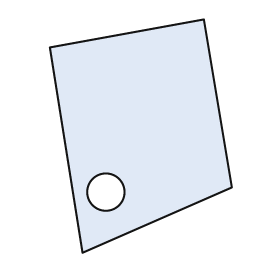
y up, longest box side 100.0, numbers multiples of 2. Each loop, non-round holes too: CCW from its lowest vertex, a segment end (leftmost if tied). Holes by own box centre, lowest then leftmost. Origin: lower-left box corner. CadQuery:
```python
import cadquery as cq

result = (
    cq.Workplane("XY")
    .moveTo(14.0, 0.0)
    .lineTo(78.0, 28.0)
    .lineTo(66.0, 100.0)
    .lineTo(0.0, 88.0)
    .close()
    .moveTo(24.0, 26.0)
    .circle(8.0)
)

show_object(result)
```